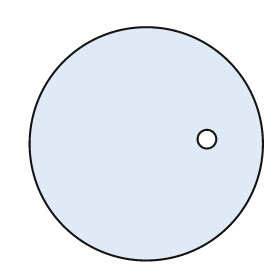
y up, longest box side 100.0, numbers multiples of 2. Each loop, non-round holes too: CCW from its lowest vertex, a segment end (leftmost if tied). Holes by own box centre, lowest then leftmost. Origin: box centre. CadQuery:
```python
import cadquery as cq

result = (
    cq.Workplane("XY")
    .moveTo(0.0, 0.0)
    .circle(50.0)
    .moveTo(26.0, 2.0)
    .circle(4.0)
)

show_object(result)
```